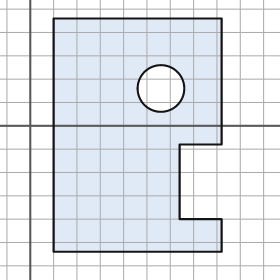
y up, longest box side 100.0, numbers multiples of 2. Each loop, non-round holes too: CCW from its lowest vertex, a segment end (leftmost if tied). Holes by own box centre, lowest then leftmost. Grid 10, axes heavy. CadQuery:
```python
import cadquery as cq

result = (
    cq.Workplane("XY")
    .moveTo(10.0, -54.0)
    .lineTo(82.0, -54.0)
    .lineTo(82.0, -40.0)
    .lineTo(64.0, -40.0)
    .lineTo(64.0, -8.0)
    .lineTo(82.0, -8.0)
    .lineTo(82.0, 46.0)
    .lineTo(10.0, 46.0)
    .close()
    .moveTo(56.0, 16.0)
    .circle(10.0)
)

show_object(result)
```